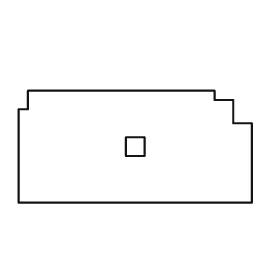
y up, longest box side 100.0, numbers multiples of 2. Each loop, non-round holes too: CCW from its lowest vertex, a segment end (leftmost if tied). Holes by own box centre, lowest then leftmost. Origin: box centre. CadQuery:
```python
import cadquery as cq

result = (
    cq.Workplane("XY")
    .moveTo(-50.0, -24.0)
    .lineTo(50.0, -24.0)
    .lineTo(50.0, 10.0)
    .lineTo(42.0, 10.0)
    .lineTo(42.0, 20.0)
    .lineTo(34.0, 20.0)
    .lineTo(34.0, 24.0)
    .lineTo(-46.0, 24.0)
    .lineTo(-46.0, 16.0)
    .lineTo(-50.0, 16.0)
    .close()
    .moveTo(-4.0, -4.0)
    .lineTo(4.0, -4.0)
    .lineTo(4.0, 4.0)
    .lineTo(-4.0, 4.0)
    .close()
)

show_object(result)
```